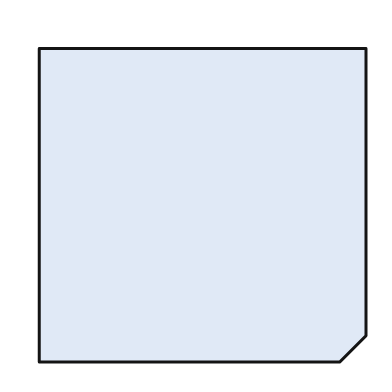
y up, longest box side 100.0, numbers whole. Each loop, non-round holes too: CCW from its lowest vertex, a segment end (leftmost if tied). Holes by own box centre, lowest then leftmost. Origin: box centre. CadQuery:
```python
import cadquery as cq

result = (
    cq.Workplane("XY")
    .moveTo(-50.0, -48.0)
    .lineTo(42.0, -48.0)
    .lineTo(50.0, -40.0)
    .lineTo(50.0, 48.0)
    .lineTo(-50.0, 48.0)
    .close()
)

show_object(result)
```